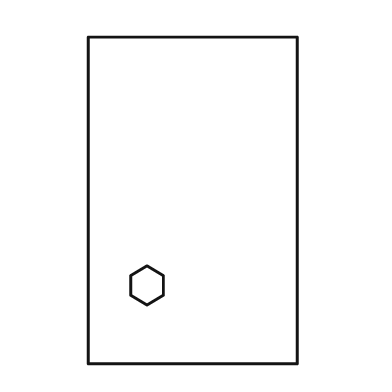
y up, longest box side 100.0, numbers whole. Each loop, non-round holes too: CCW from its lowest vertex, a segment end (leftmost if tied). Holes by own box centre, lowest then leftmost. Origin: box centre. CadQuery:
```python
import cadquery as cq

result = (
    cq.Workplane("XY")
    .moveTo(-32.0, -50.0)
    .lineTo(32.0, -50.0)
    .lineTo(32.0, 50.0)
    .lineTo(-32.0, 50.0)
    .close()
    .moveTo(-14.0, -32.0)
    .lineTo(-9.0, -29.0)
    .lineTo(-9.0, -23.0)
    .lineTo(-14.0, -20.0)
    .lineTo(-19.0, -23.0)
    .lineTo(-19.0, -29.0)
    .close()
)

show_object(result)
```